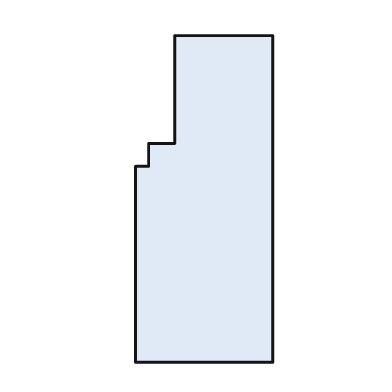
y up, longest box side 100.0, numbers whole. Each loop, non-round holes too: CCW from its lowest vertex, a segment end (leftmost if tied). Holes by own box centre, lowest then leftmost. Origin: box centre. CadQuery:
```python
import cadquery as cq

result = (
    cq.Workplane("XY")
    .moveTo(-21.0, -50.0)
    .lineTo(21.0, -50.0)
    .lineTo(21.0, 50.0)
    .lineTo(-9.0, 50.0)
    .lineTo(-9.0, 17.0)
    .lineTo(-17.0, 17.0)
    .lineTo(-17.0, 10.0)
    .lineTo(-21.0, 10.0)
    .close()
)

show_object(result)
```